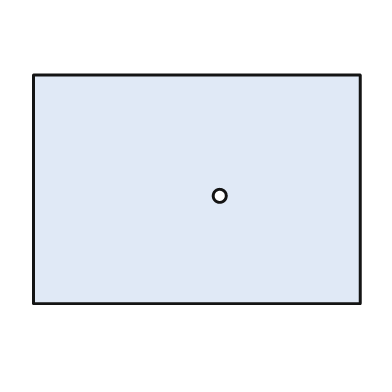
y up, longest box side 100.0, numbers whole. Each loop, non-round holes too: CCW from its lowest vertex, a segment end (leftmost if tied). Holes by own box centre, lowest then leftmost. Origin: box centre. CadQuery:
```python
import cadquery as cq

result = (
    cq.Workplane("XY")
    .moveTo(-50.0, -35.0)
    .lineTo(50.0, -35.0)
    .lineTo(50.0, 35.0)
    .lineTo(-50.0, 35.0)
    .close()
    .moveTo(7.0, -2.0)
    .circle(2.0)
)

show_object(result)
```